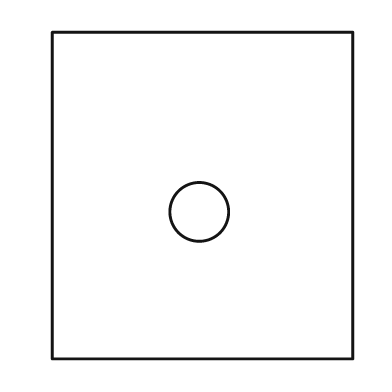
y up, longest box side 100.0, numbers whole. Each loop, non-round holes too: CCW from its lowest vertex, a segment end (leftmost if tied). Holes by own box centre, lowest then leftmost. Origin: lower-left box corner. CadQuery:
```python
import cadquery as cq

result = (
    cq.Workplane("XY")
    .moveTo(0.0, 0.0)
    .lineTo(92.0, 0.0)
    .lineTo(92.0, 100.0)
    .lineTo(0.0, 100.0)
    .close()
    .moveTo(45.0, 45.0)
    .circle(9.0)
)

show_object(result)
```